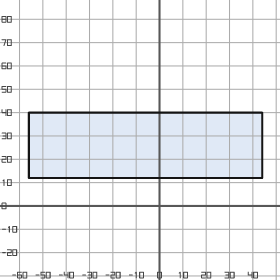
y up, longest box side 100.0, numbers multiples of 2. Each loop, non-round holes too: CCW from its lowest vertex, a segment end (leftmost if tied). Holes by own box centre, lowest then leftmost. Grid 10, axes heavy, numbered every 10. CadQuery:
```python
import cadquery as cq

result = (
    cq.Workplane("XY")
    .moveTo(-56.0, 12.0)
    .lineTo(44.0, 12.0)
    .lineTo(44.0, 40.0)
    .lineTo(-56.0, 40.0)
    .close()
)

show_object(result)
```